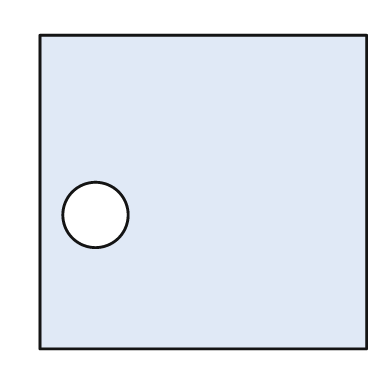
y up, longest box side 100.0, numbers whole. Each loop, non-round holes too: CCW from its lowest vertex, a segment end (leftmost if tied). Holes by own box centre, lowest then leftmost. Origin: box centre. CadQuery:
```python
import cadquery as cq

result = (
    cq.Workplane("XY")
    .moveTo(-50.0, -48.0)
    .lineTo(50.0, -48.0)
    .lineTo(50.0, 48.0)
    .lineTo(-50.0, 48.0)
    .close()
    .moveTo(-33.0, -7.0)
    .circle(10.0)
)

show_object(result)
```